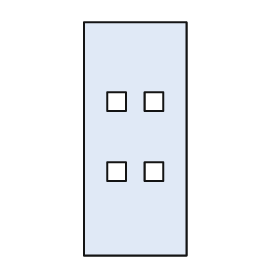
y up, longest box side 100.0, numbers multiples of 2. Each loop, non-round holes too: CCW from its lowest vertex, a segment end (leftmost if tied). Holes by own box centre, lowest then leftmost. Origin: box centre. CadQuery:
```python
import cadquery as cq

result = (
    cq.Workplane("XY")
    .moveTo(-22.0, -50.0)
    .lineTo(22.0, -50.0)
    .lineTo(22.0, 50.0)
    .lineTo(-22.0, 50.0)
    .close()
    .moveTo(-12.0, -18.0)
    .lineTo(-4.0, -18.0)
    .lineTo(-4.0, -10.0)
    .lineTo(-12.0, -10.0)
    .close()
    .moveTo(4.0, -18.0)
    .lineTo(12.0, -18.0)
    .lineTo(12.0, -10.0)
    .lineTo(4.0, -10.0)
    .close()
    .moveTo(-12.0, 12.0)
    .lineTo(-4.0, 12.0)
    .lineTo(-4.0, 20.0)
    .lineTo(-12.0, 20.0)
    .close()
    .moveTo(4.0, 12.0)
    .lineTo(12.0, 12.0)
    .lineTo(12.0, 20.0)
    .lineTo(4.0, 20.0)
    .close()
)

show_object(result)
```